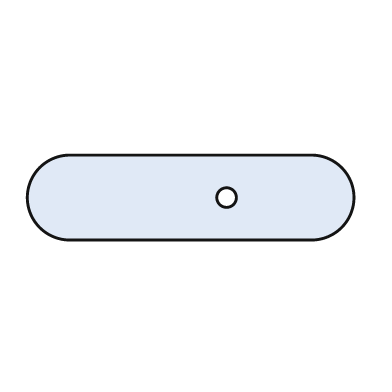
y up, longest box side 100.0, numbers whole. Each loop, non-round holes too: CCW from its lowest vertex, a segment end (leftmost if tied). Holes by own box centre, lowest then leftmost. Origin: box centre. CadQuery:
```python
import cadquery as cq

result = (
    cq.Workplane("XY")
    .moveTo(-37.0, -13.0)
    .lineTo(37.0, -13.0)
    .threePointArc((50.0, 0.0), (37.0, 13.0))
    .lineTo(-37.0, 13.0)
    .threePointArc((-50.0, 0.0), (-37.0, -13.0))
    .close()
    .moveTo(11.0, 0.0)
    .circle(3.0)
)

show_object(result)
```